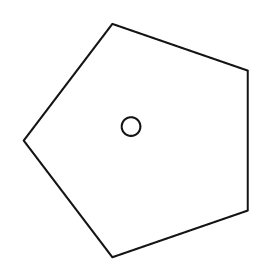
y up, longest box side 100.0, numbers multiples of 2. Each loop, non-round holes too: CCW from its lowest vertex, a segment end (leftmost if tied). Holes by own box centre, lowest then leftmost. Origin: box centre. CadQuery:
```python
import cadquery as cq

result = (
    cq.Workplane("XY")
    .moveTo(-10.0, -50.0)
    .lineTo(48.0, -30.0)
    .lineTo(48.0, 30.0)
    .lineTo(-10.0, 50.0)
    .lineTo(-48.0, 0.0)
    .close()
    .moveTo(-2.0, 6.0)
    .circle(4.0)
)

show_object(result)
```